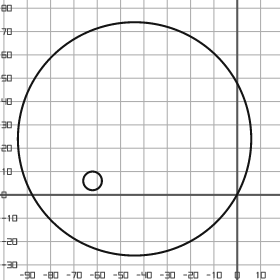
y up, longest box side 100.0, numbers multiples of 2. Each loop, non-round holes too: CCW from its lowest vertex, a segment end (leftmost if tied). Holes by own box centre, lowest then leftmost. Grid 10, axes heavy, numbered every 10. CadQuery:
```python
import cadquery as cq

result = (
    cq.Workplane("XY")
    .moveTo(-44.0, 24.0)
    .circle(50.0)
    .moveTo(-62.0, 6.0)
    .circle(4.0)
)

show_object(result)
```